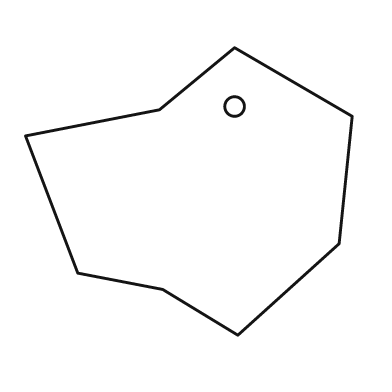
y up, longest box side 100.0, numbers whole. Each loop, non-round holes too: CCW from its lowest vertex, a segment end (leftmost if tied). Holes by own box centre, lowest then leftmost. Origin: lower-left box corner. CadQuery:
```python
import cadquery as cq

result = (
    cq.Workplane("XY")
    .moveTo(65.0, 0.0)
    .lineTo(96.0, 28.0)
    .lineTo(100.0, 67.0)
    .lineTo(64.0, 88.0)
    .lineTo(41.0, 69.0)
    .lineTo(0.0, 61.0)
    .lineTo(16.0, 19.0)
    .lineTo(42.0, 14.0)
    .close()
    .moveTo(64.0, 70.0)
    .circle(3.0)
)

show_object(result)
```